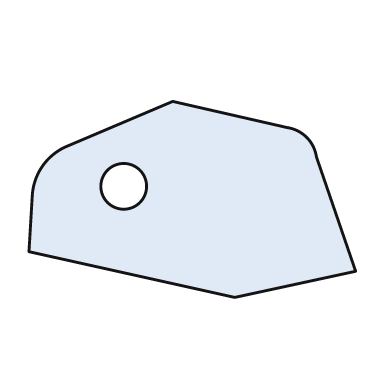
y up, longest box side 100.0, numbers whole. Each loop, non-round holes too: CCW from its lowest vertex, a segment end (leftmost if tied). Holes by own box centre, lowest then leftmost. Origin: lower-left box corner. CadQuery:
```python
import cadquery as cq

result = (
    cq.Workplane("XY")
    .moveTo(63.0, 0.0)
    .lineTo(100.0, 8.0)
    .lineTo(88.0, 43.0)
    .threePointArc((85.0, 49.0), (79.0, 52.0))
    .lineTo(44.0, 60.0)
    .lineTo(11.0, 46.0)
    .threePointArc((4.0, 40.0), (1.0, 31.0))
    .lineTo(0.0, 14.0)
    .close()
    .moveTo(29.0, 34.0)
    .circle(7.0)
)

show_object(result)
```